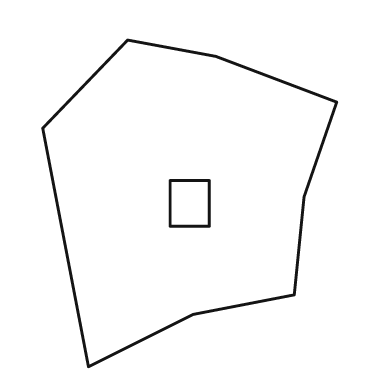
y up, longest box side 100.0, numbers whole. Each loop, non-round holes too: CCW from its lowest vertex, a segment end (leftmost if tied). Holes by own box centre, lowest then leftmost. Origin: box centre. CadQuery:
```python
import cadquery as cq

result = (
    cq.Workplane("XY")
    .moveTo(-31.0, -50.0)
    .lineTo(1.0, -34.0)
    .lineTo(32.0, -28.0)
    .lineTo(35.0, 2.0)
    .lineTo(45.0, 31.0)
    .lineTo(8.0, 45.0)
    .lineTo(-19.0, 50.0)
    .lineTo(-45.0, 23.0)
    .close()
    .moveTo(-6.0, -7.0)
    .lineTo(6.0, -7.0)
    .lineTo(6.0, 7.0)
    .lineTo(-6.0, 7.0)
    .close()
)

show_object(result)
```